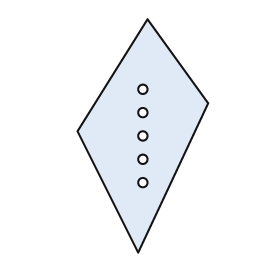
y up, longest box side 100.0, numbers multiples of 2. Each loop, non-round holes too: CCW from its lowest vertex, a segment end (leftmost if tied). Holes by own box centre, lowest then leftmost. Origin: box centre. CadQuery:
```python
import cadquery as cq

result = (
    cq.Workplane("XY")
    .moveTo(-2.0, -50.0)
    .lineTo(28.0, 14.0)
    .lineTo(2.0, 50.0)
    .lineTo(-28.0, 2.0)
    .close()
    .moveTo(0.0, -20.0)
    .circle(2.0)
    .moveTo(0.0, -10.0)
    .circle(2.0)
    .moveTo(0.0, 0.0)
    .circle(2.0)
    .moveTo(0.0, 10.0)
    .circle(2.0)
    .moveTo(0.0, 20.0)
    .circle(2.0)
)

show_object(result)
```